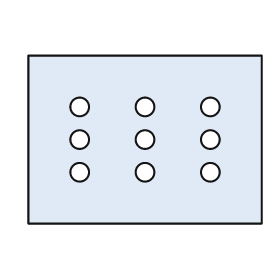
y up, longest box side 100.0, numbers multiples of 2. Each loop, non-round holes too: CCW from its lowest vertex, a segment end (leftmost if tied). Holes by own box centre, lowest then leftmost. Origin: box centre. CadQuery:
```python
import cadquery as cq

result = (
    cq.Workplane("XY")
    .moveTo(-50.0, -36.0)
    .lineTo(50.0, -36.0)
    .lineTo(50.0, 36.0)
    .lineTo(-50.0, 36.0)
    .close()
    .moveTo(-28.0, -14.0)
    .circle(4.0)
    .moveTo(0.0, -14.0)
    .circle(4.0)
    .moveTo(28.0, -14.0)
    .circle(4.0)
    .moveTo(-28.0, 0.0)
    .circle(4.0)
    .moveTo(0.0, 0.0)
    .circle(4.0)
    .moveTo(28.0, 0.0)
    .circle(4.0)
    .moveTo(-28.0, 14.0)
    .circle(4.0)
    .moveTo(0.0, 14.0)
    .circle(4.0)
    .moveTo(28.0, 14.0)
    .circle(4.0)
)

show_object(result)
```